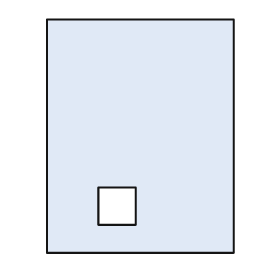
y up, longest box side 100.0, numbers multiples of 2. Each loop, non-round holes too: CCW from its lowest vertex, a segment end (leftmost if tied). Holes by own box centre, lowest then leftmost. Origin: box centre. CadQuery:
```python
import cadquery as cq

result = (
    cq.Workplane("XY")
    .moveTo(-40.0, -50.0)
    .lineTo(40.0, -50.0)
    .lineTo(40.0, 50.0)
    .lineTo(-40.0, 50.0)
    .close()
    .moveTo(-18.0, -38.0)
    .lineTo(-2.0, -38.0)
    .lineTo(-2.0, -22.0)
    .lineTo(-18.0, -22.0)
    .close()
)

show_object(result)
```